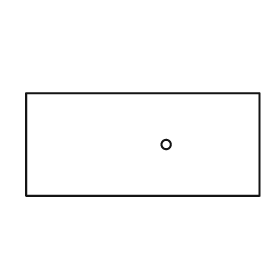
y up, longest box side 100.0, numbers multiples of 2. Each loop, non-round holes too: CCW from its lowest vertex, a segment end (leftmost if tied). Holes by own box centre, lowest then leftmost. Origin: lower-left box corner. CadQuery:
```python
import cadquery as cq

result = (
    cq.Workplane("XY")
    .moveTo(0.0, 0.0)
    .lineTo(100.0, 0.0)
    .lineTo(100.0, 44.0)
    .lineTo(0.0, 44.0)
    .close()
    .moveTo(60.0, 22.0)
    .circle(2.0)
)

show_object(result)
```